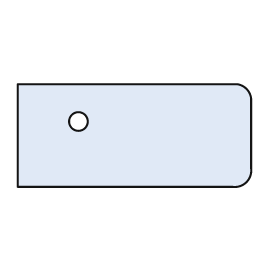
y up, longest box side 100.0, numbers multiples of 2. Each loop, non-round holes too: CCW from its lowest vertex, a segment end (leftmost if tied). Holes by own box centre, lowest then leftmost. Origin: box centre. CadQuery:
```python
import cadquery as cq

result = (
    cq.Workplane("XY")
    .moveTo(-50.0, -22.0)
    .lineTo(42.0, -22.0)
    .threePointArc((48.0, -20.0), (50.0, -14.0))
    .lineTo(50.0, 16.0)
    .threePointArc((48.0, 20.0), (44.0, 22.0))
    .lineTo(-50.0, 22.0)
    .close()
    .moveTo(-24.0, 6.0)
    .circle(4.0)
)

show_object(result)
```